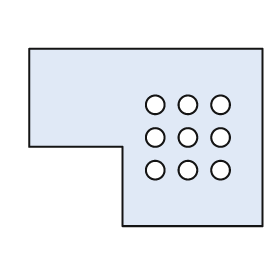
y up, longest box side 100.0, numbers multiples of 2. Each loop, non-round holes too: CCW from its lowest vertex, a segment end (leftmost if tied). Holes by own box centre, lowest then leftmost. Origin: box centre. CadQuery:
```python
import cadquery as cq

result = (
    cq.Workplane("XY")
    .moveTo(-10.0, -38.0)
    .lineTo(50.0, -38.0)
    .lineTo(50.0, 38.0)
    .lineTo(-50.0, 38.0)
    .lineTo(-50.0, -4.0)
    .lineTo(-10.0, -4.0)
    .close()
    .moveTo(4.0, -14.0)
    .circle(4.0)
    .moveTo(18.0, -14.0)
    .circle(4.0)
    .moveTo(32.0, -14.0)
    .circle(4.0)
    .moveTo(4.0, 0.0)
    .circle(4.0)
    .moveTo(18.0, 0.0)
    .circle(4.0)
    .moveTo(32.0, 0.0)
    .circle(4.0)
    .moveTo(4.0, 14.0)
    .circle(4.0)
    .moveTo(18.0, 14.0)
    .circle(4.0)
    .moveTo(32.0, 14.0)
    .circle(4.0)
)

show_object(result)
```